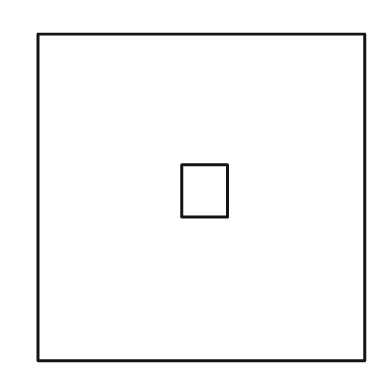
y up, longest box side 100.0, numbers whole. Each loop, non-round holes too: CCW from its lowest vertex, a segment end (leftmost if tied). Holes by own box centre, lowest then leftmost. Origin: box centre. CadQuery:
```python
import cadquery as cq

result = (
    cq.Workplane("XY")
    .moveTo(-50.0, -50.0)
    .lineTo(50.0, -50.0)
    .lineTo(50.0, 50.0)
    .lineTo(-50.0, 50.0)
    .close()
    .moveTo(-6.0, -6.0)
    .lineTo(8.0, -6.0)
    .lineTo(8.0, 10.0)
    .lineTo(-6.0, 10.0)
    .close()
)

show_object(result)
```